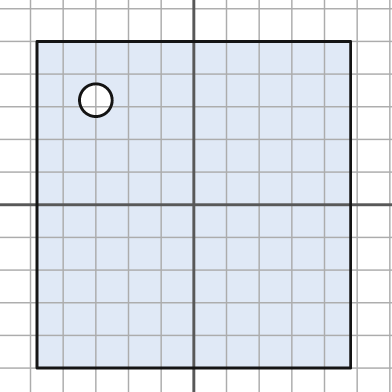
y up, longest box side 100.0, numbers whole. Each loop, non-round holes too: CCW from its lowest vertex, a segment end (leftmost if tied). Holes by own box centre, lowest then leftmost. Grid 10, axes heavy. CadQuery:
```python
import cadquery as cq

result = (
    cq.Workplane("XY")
    .moveTo(-48.0, -50.0)
    .lineTo(48.0, -50.0)
    .lineTo(48.0, 50.0)
    .lineTo(-48.0, 50.0)
    .close()
    .moveTo(-30.0, 32.0)
    .circle(5.0)
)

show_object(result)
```